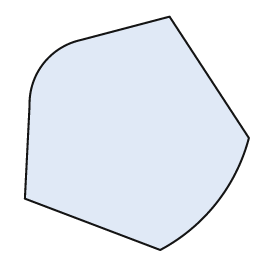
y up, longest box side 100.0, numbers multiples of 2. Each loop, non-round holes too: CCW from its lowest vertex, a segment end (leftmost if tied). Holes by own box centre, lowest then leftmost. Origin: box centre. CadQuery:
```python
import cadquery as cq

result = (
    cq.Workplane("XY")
    .moveTo(10.0, -50.0)
    .threePointArc((34.0, -30.0), (48.0, -2.0))
    .lineTo(14.0, 50.0)
    .lineTo(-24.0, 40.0)
    .threePointArc((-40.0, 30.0), (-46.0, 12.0))
    .lineTo(-48.0, -28.0)
    .close()
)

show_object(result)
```